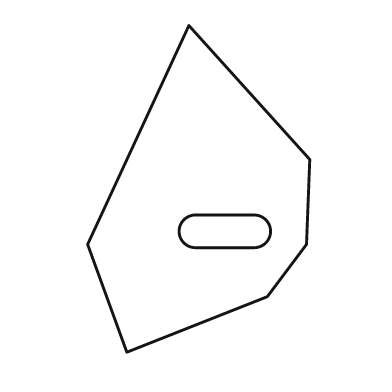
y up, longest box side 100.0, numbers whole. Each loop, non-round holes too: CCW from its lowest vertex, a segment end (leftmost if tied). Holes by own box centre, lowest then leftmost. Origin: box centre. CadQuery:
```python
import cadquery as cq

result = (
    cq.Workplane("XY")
    .moveTo(-22.0, -50.0)
    .lineTo(21.0, -33.0)
    .lineTo(33.0, -17.0)
    .lineTo(34.0, 9.0)
    .lineTo(-3.0, 50.0)
    .lineTo(-34.0, -17.0)
    .close()
    .moveTo(-1.0, -18.0)
    .lineTo(17.0, -18.0)
    .threePointArc((22.0, -13.0), (17.0, -8.0))
    .lineTo(-1.0, -8.0)
    .threePointArc((-6.0, -13.0), (-1.0, -18.0))
    .close()
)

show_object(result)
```